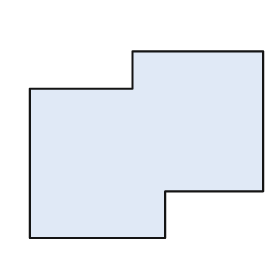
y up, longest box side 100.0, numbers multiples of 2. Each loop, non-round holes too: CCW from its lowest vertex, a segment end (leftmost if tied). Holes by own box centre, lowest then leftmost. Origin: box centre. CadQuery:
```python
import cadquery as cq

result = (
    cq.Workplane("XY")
    .moveTo(-50.0, -40.0)
    .lineTo(8.0, -40.0)
    .lineTo(8.0, -20.0)
    .lineTo(50.0, -20.0)
    .lineTo(50.0, 40.0)
    .lineTo(-6.0, 40.0)
    .lineTo(-6.0, 24.0)
    .lineTo(-50.0, 24.0)
    .close()
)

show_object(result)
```